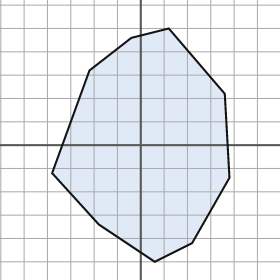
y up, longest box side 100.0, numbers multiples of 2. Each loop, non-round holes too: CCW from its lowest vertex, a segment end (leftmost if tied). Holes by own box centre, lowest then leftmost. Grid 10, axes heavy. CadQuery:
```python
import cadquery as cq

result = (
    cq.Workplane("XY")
    .moveTo(6.0, -50.0)
    .lineTo(22.0, -42.0)
    .lineTo(38.0, -14.0)
    .lineTo(36.0, 22.0)
    .lineTo(12.0, 50.0)
    .lineTo(-4.0, 46.0)
    .lineTo(-22.0, 32.0)
    .lineTo(-38.0, -12.0)
    .lineTo(-18.0, -34.0)
    .close()
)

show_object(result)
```